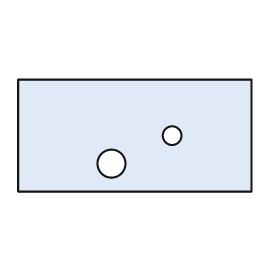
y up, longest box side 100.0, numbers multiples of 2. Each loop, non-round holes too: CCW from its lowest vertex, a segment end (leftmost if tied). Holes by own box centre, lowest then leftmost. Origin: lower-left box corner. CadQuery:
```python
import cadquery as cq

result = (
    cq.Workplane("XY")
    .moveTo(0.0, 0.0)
    .lineTo(100.0, 0.0)
    .lineTo(100.0, 48.0)
    .lineTo(0.0, 48.0)
    .close()
    .moveTo(40.0, 12.0)
    .circle(6.0)
    .moveTo(66.0, 24.0)
    .circle(4.0)
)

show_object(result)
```